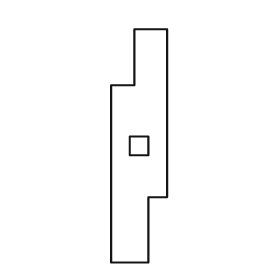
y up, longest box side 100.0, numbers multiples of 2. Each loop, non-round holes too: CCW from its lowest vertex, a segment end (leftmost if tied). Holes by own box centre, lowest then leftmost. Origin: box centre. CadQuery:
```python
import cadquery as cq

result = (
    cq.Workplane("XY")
    .moveTo(-12.0, -50.0)
    .lineTo(4.0, -50.0)
    .lineTo(4.0, -22.0)
    .lineTo(12.0, -22.0)
    .lineTo(12.0, 50.0)
    .lineTo(-2.0, 50.0)
    .lineTo(-2.0, 26.0)
    .lineTo(-12.0, 26.0)
    .close()
    .moveTo(-4.0, -4.0)
    .lineTo(4.0, -4.0)
    .lineTo(4.0, 4.0)
    .lineTo(-4.0, 4.0)
    .close()
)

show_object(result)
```